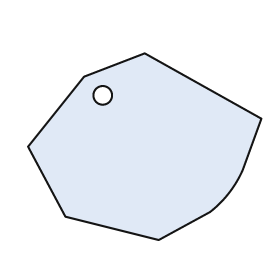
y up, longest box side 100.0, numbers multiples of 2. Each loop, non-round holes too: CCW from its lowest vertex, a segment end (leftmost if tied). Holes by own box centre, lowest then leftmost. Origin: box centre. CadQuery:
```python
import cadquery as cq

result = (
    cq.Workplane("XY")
    .moveTo(6.0, -40.0)
    .lineTo(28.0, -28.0)
    .threePointArc((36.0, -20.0), (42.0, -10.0))
    .lineTo(50.0, 12.0)
    .lineTo(0.0, 40.0)
    .lineTo(-26.0, 30.0)
    .lineTo(-50.0, 0.0)
    .lineTo(-34.0, -30.0)
    .close()
    .moveTo(-18.0, 22.0)
    .circle(4.0)
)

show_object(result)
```